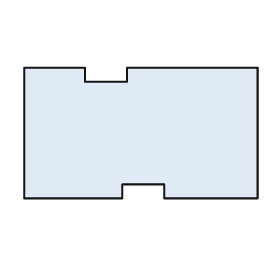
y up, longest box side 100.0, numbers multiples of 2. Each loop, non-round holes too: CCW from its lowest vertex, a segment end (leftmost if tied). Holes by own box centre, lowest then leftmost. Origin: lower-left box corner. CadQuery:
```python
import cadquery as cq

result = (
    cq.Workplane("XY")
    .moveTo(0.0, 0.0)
    .lineTo(42.0, 0.0)
    .lineTo(42.0, 6.0)
    .lineTo(60.0, 6.0)
    .lineTo(60.0, 0.0)
    .lineTo(100.0, 0.0)
    .lineTo(100.0, 56.0)
    .lineTo(44.0, 56.0)
    .lineTo(44.0, 50.0)
    .lineTo(26.0, 50.0)
    .lineTo(26.0, 56.0)
    .lineTo(0.0, 56.0)
    .close()
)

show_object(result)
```